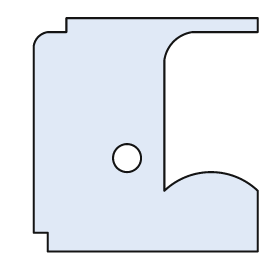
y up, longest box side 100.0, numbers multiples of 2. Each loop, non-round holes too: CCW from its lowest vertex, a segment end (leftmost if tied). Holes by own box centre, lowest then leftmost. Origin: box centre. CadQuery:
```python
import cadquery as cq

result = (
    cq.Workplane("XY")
    .moveTo(-42.0, -50.0)
    .lineTo(48.0, -50.0)
    .lineTo(48.0, -24.0)
    .threePointArc((28.0, -16.0), (8.0, -24.0))
    .lineTo(8.0, 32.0)
    .threePointArc((12.0, 40.0), (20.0, 44.0))
    .lineTo(48.0, 44.0)
    .lineTo(48.0, 50.0)
    .lineTo(-34.0, 50.0)
    .lineTo(-34.0, 44.0)
    .lineTo(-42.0, 44.0)
    .threePointArc((-46.0, 42.0), (-48.0, 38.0))
    .lineTo(-48.0, -42.0)
    .lineTo(-42.0, -42.0)
    .close()
    .moveTo(-8.0, -10.0)
    .circle(6.0)
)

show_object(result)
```